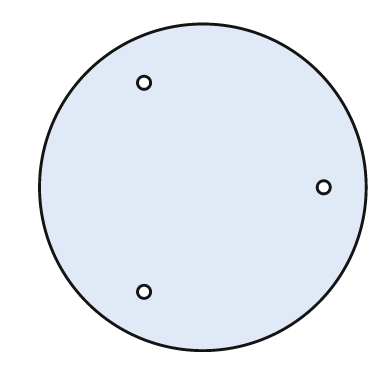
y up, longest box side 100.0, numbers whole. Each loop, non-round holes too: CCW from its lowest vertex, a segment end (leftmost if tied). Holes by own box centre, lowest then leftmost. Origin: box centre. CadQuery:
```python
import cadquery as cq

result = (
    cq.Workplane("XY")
    .moveTo(0.0, 0.0)
    .circle(50.0)
    .moveTo(-18.0, -32.0)
    .circle(2.0)
    .moveTo(37.0, 0.0)
    .circle(2.0)
    .moveTo(-18.0, 32.0)
    .circle(2.0)
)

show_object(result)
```